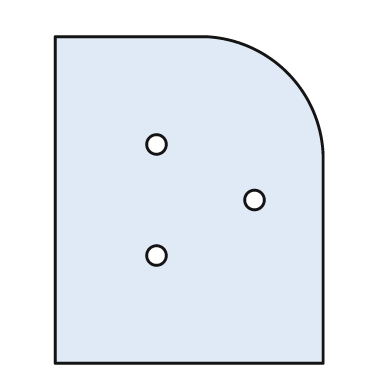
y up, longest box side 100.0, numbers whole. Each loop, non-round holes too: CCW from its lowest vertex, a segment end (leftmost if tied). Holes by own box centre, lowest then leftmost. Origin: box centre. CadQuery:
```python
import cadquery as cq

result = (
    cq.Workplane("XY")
    .moveTo(-41.0, -50.0)
    .lineTo(41.0, -50.0)
    .lineTo(41.0, 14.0)
    .threePointArc((30.0, 39.0), (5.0, 50.0))
    .lineTo(-41.0, 50.0)
    .close()
    .moveTo(-10.0, -17.0)
    .circle(3.0)
    .moveTo(20.0, 0.0)
    .circle(3.0)
    .moveTo(-10.0, 17.0)
    .circle(3.0)
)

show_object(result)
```